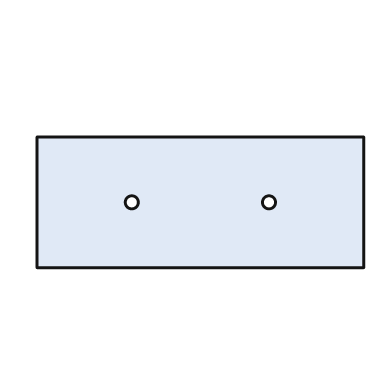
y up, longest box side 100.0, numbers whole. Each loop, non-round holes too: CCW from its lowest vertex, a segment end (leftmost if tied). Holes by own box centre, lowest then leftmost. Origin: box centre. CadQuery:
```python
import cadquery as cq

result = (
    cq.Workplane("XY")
    .moveTo(-50.0, -20.0)
    .lineTo(50.0, -20.0)
    .lineTo(50.0, 20.0)
    .lineTo(-50.0, 20.0)
    .close()
    .moveTo(-21.0, 0.0)
    .circle(2.0)
    .moveTo(21.0, 0.0)
    .circle(2.0)
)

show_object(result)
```